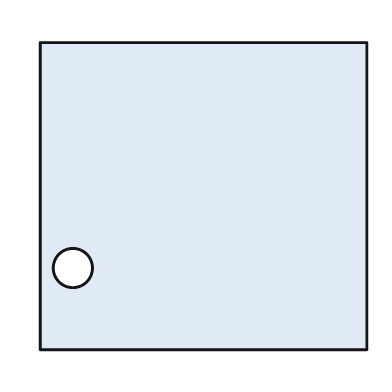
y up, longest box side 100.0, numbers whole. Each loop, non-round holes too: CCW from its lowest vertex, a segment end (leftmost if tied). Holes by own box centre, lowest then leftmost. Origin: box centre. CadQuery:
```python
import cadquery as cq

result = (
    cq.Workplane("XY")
    .moveTo(-50.0, -47.0)
    .lineTo(50.0, -47.0)
    .lineTo(50.0, 47.0)
    .lineTo(-50.0, 47.0)
    .close()
    .moveTo(-40.0, -22.0)
    .circle(6.0)
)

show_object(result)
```